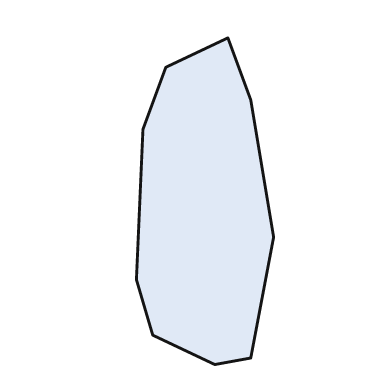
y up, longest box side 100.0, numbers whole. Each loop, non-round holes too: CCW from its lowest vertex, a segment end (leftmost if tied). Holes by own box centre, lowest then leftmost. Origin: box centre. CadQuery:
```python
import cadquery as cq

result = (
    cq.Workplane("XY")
    .moveTo(3.0, -50.0)
    .lineTo(14.0, -48.0)
    .lineTo(21.0, -11.0)
    .lineTo(14.0, 31.0)
    .lineTo(7.0, 50.0)
    .lineTo(-12.0, 41.0)
    .lineTo(-19.0, 22.0)
    .lineTo(-21.0, -24.0)
    .lineTo(-16.0, -41.0)
    .close()
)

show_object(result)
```